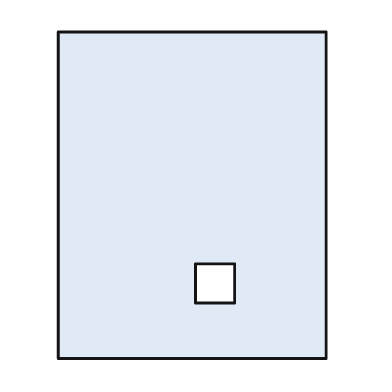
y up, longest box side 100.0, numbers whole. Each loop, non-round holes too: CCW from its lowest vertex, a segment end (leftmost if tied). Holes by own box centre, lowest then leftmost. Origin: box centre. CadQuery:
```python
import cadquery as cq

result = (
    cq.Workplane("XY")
    .moveTo(-41.0, -50.0)
    .lineTo(41.0, -50.0)
    .lineTo(41.0, 50.0)
    .lineTo(-41.0, 50.0)
    .close()
    .moveTo(1.0, -33.0)
    .lineTo(13.0, -33.0)
    .lineTo(13.0, -21.0)
    .lineTo(1.0, -21.0)
    .close()
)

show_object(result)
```